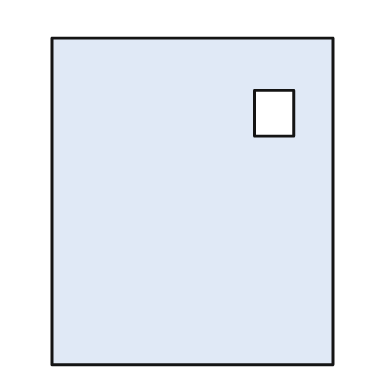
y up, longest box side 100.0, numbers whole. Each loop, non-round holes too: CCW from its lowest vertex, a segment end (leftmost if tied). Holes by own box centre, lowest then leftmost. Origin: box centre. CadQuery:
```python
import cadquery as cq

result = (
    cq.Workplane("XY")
    .moveTo(-43.0, -50.0)
    .lineTo(43.0, -50.0)
    .lineTo(43.0, 50.0)
    .lineTo(-43.0, 50.0)
    .close()
    .moveTo(19.0, 20.0)
    .lineTo(31.0, 20.0)
    .lineTo(31.0, 34.0)
    .lineTo(19.0, 34.0)
    .close()
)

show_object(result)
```